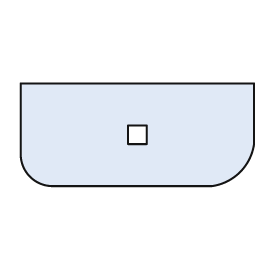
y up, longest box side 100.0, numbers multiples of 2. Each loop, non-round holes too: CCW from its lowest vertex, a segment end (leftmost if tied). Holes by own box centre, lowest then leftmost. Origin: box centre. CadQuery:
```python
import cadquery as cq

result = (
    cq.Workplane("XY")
    .moveTo(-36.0, -22.0)
    .lineTo(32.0, -22.0)
    .threePointArc((44.0, -16.0), (50.0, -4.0))
    .lineTo(50.0, 22.0)
    .lineTo(-50.0, 22.0)
    .lineTo(-50.0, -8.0)
    .threePointArc((-46.0, -18.0), (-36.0, -22.0))
    .close()
    .moveTo(-4.0, -4.0)
    .lineTo(4.0, -4.0)
    .lineTo(4.0, 4.0)
    .lineTo(-4.0, 4.0)
    .close()
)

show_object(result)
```